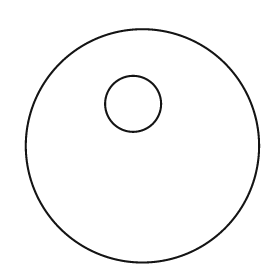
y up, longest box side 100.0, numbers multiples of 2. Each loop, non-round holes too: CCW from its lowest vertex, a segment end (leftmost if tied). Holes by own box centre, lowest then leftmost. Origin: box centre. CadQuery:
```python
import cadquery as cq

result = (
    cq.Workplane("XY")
    .moveTo(0.0, 0.0)
    .circle(50.0)
    .moveTo(-4.0, 18.0)
    .circle(12.0)
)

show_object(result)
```